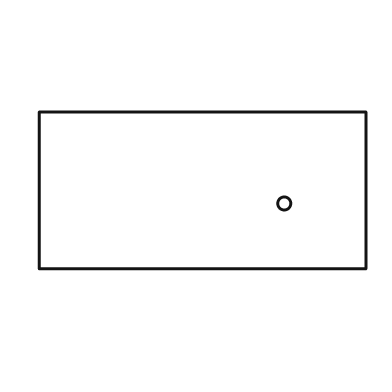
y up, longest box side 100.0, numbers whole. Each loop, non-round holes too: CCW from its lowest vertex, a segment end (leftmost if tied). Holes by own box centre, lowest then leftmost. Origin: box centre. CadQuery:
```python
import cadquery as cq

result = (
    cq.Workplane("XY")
    .moveTo(-50.0, -24.0)
    .lineTo(50.0, -24.0)
    .lineTo(50.0, 24.0)
    .lineTo(-50.0, 24.0)
    .close()
    .moveTo(25.0, -4.0)
    .circle(2.0)
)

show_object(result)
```